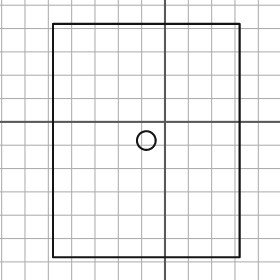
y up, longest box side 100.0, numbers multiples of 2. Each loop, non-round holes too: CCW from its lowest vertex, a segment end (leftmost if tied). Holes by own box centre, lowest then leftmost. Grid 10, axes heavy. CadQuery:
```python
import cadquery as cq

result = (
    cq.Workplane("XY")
    .moveTo(-48.0, -58.0)
    .lineTo(32.0, -58.0)
    .lineTo(32.0, 42.0)
    .lineTo(-48.0, 42.0)
    .close()
    .moveTo(-8.0, -8.0)
    .circle(4.0)
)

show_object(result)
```